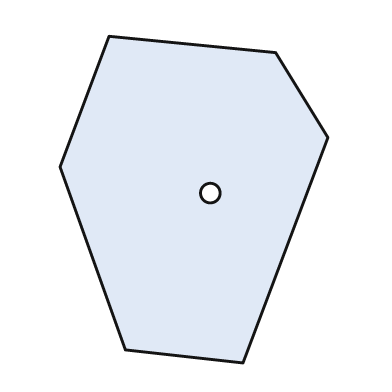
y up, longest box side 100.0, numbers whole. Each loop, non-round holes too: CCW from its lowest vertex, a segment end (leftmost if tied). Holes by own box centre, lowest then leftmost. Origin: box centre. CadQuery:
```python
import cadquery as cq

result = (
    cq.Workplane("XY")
    .moveTo(15.0, -50.0)
    .lineTo(41.0, 19.0)
    .lineTo(25.0, 45.0)
    .lineTo(-26.0, 50.0)
    .lineTo(-41.0, 10.0)
    .lineTo(-21.0, -46.0)
    .close()
    .moveTo(5.0, 2.0)
    .circle(3.0)
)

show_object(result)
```